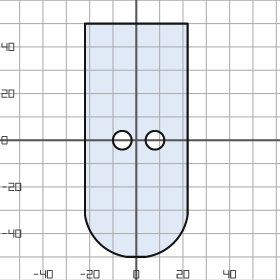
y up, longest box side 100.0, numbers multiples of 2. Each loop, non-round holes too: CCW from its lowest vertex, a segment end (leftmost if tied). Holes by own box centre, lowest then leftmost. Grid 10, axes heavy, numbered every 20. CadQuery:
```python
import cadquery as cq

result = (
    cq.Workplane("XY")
    .moveTo(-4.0, -50.0)
    .lineTo(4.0, -50.0)
    .threePointArc((16.0, -44.0), (22.0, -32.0))
    .lineTo(22.0, 50.0)
    .lineTo(-22.0, 50.0)
    .lineTo(-22.0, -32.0)
    .threePointArc((-16.0, -44.0), (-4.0, -50.0))
    .close()
    .moveTo(-6.0, 0.0)
    .circle(4.0)
    .moveTo(8.0, 0.0)
    .circle(4.0)
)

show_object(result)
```